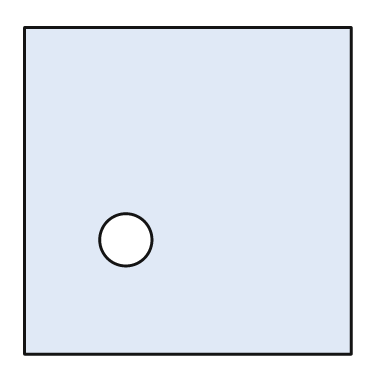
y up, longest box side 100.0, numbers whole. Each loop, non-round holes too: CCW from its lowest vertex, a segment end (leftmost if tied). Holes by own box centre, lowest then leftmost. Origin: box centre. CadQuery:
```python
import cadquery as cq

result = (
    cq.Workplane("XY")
    .moveTo(-50.0, -50.0)
    .lineTo(50.0, -50.0)
    .lineTo(50.0, 50.0)
    .lineTo(-50.0, 50.0)
    .close()
    .moveTo(-19.0, -15.0)
    .circle(8.0)
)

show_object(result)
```